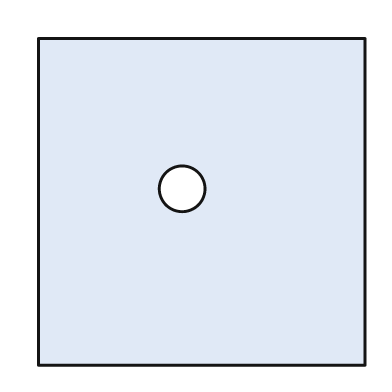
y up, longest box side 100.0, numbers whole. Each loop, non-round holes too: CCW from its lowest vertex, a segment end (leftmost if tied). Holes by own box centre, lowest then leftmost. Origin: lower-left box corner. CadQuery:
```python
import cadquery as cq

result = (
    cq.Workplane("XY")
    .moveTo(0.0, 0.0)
    .lineTo(100.0, 0.0)
    .lineTo(100.0, 100.0)
    .lineTo(0.0, 100.0)
    .close()
    .moveTo(44.0, 54.0)
    .circle(7.0)
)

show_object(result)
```